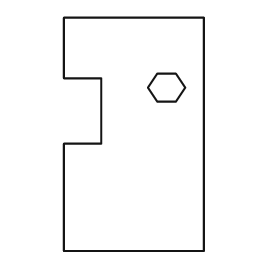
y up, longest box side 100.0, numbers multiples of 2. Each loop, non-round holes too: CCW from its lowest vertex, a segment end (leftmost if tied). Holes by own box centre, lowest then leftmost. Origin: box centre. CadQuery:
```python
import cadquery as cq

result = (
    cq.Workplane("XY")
    .moveTo(-30.0, -50.0)
    .lineTo(30.0, -50.0)
    .lineTo(30.0, 50.0)
    .lineTo(-30.0, 50.0)
    .lineTo(-30.0, 24.0)
    .lineTo(-14.0, 24.0)
    .lineTo(-14.0, -4.0)
    .lineTo(-30.0, -4.0)
    .close()
    .moveTo(10.0, 14.0)
    .lineTo(18.0, 14.0)
    .lineTo(22.0, 20.0)
    .lineTo(18.0, 26.0)
    .lineTo(10.0, 26.0)
    .lineTo(6.0, 20.0)
    .close()
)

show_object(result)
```